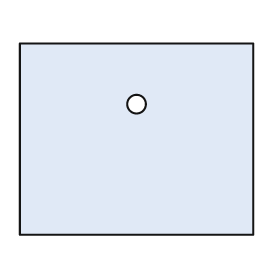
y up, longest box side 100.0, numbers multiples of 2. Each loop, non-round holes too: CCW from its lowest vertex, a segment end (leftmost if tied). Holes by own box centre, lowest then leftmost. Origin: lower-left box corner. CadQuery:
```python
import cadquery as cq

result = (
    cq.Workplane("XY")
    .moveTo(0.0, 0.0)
    .lineTo(100.0, 0.0)
    .lineTo(100.0, 82.0)
    .lineTo(0.0, 82.0)
    .close()
    .moveTo(50.0, 56.0)
    .circle(4.0)
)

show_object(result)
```